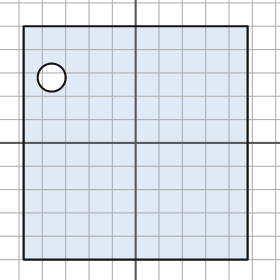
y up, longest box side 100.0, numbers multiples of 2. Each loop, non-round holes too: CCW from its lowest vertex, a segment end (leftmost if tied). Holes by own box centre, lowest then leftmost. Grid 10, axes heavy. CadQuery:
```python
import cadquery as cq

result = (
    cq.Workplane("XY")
    .moveTo(-48.0, -50.0)
    .lineTo(48.0, -50.0)
    .lineTo(48.0, 50.0)
    .lineTo(-48.0, 50.0)
    .close()
    .moveTo(-36.0, 28.0)
    .circle(6.0)
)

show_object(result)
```